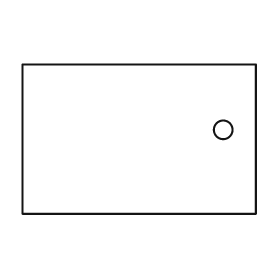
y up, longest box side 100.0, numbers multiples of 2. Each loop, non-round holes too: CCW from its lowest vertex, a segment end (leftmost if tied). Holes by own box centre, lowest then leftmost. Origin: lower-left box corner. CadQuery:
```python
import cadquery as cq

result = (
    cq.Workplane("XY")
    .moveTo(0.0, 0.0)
    .lineTo(100.0, 0.0)
    .lineTo(100.0, 64.0)
    .lineTo(0.0, 64.0)
    .close()
    .moveTo(86.0, 36.0)
    .circle(4.0)
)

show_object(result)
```